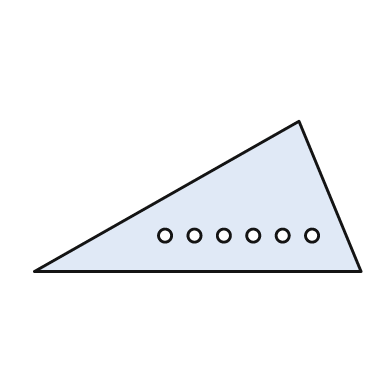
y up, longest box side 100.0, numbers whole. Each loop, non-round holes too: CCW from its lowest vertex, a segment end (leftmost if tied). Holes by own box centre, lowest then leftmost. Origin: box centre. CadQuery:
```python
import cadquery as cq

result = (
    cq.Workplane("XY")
    .moveTo(-50.0, -23.0)
    .lineTo(50.0, -23.0)
    .lineTo(31.0, 23.0)
    .close()
    .moveTo(-10.0, -12.0)
    .circle(2.0)
    .moveTo(-1.0, -12.0)
    .circle(2.0)
    .moveTo(8.0, -12.0)
    .circle(2.0)
    .moveTo(17.0, -12.0)
    .circle(2.0)
    .moveTo(26.0, -12.0)
    .circle(2.0)
    .moveTo(35.0, -12.0)
    .circle(2.0)
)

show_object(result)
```